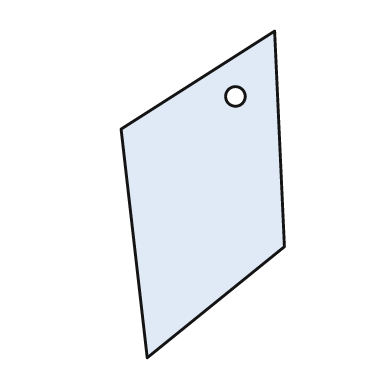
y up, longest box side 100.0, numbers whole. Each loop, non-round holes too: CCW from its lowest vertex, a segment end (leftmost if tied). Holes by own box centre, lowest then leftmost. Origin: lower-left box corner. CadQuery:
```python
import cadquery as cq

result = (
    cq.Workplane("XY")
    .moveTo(8.0, 0.0)
    .lineTo(50.0, 34.0)
    .lineTo(47.0, 100.0)
    .lineTo(0.0, 70.0)
    .close()
    .moveTo(35.0, 80.0)
    .circle(3.0)
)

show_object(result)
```